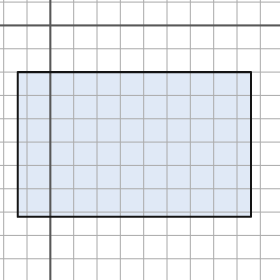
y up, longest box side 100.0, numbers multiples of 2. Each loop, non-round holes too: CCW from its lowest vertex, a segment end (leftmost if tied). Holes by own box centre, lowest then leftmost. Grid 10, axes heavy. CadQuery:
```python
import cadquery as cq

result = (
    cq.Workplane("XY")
    .moveTo(-14.0, -82.0)
    .lineTo(86.0, -82.0)
    .lineTo(86.0, -20.0)
    .lineTo(-14.0, -20.0)
    .close()
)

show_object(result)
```